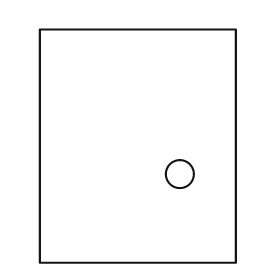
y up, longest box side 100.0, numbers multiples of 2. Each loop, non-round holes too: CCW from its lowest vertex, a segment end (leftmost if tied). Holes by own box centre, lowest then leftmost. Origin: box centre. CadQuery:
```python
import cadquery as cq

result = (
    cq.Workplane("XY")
    .moveTo(-42.0, -50.0)
    .lineTo(42.0, -50.0)
    .lineTo(42.0, 50.0)
    .lineTo(-42.0, 50.0)
    .close()
    .moveTo(18.0, -12.0)
    .circle(6.0)
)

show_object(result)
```